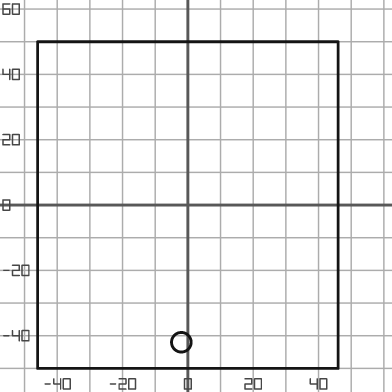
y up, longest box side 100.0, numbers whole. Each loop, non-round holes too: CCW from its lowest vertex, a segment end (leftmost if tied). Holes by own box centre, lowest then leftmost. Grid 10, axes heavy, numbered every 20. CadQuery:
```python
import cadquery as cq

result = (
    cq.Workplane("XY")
    .moveTo(-46.0, -50.0)
    .lineTo(46.0, -50.0)
    .lineTo(46.0, 50.0)
    .lineTo(-46.0, 50.0)
    .close()
    .moveTo(-2.0, -42.0)
    .circle(3.0)
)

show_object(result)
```